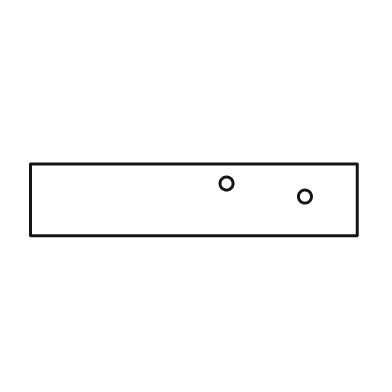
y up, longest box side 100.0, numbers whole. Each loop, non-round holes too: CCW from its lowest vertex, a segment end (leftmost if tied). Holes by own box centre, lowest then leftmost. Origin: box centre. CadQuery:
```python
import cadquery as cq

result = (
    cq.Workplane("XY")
    .moveTo(-50.0, -11.0)
    .lineTo(50.0, -11.0)
    .lineTo(50.0, 11.0)
    .lineTo(-50.0, 11.0)
    .close()
    .moveTo(34.0, 1.0)
    .circle(2.0)
    .moveTo(10.0, 5.0)
    .circle(2.0)
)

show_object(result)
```